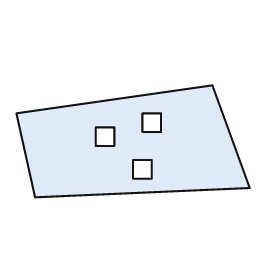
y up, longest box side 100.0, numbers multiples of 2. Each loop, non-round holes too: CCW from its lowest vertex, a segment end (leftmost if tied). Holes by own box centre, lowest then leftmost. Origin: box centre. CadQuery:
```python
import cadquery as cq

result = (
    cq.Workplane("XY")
    .moveTo(-42.0, -24.0)
    .lineTo(50.0, -20.0)
    .lineTo(34.0, 24.0)
    .lineTo(-50.0, 12.0)
    .close()
    .moveTo(0.0, -16.0)
    .lineTo(8.0, -16.0)
    .lineTo(8.0, -8.0)
    .lineTo(0.0, -8.0)
    .close()
    .moveTo(-16.0, -2.0)
    .lineTo(-8.0, -2.0)
    .lineTo(-8.0, 6.0)
    .lineTo(-16.0, 6.0)
    .close()
    .moveTo(4.0, 4.0)
    .lineTo(12.0, 4.0)
    .lineTo(12.0, 12.0)
    .lineTo(4.0, 12.0)
    .close()
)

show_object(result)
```